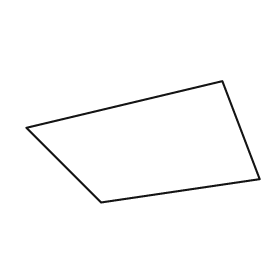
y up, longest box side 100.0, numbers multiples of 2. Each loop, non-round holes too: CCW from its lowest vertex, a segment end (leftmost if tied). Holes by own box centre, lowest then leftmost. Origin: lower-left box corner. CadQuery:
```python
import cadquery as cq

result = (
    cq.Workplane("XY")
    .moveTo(32.0, 0.0)
    .lineTo(100.0, 10.0)
    .lineTo(84.0, 52.0)
    .lineTo(0.0, 32.0)
    .close()
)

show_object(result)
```